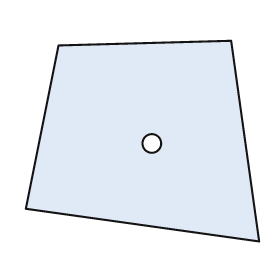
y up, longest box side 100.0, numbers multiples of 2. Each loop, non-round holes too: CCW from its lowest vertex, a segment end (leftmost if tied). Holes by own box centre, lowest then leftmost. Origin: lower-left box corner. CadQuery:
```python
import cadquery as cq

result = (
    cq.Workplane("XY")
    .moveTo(100.0, 0.0)
    .lineTo(88.0, 86.0)
    .lineTo(14.0, 84.0)
    .lineTo(0.0, 14.0)
    .close()
    .moveTo(54.0, 42.0)
    .circle(4.0)
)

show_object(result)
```